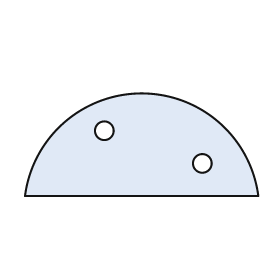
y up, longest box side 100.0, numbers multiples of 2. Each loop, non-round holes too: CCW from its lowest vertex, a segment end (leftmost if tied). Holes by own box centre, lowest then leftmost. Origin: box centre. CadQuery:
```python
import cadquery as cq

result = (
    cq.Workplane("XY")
    .moveTo(-50.0, -22.0)
    .lineTo(50.0, -22.0)
    .threePointArc((0.0, 22.0), (-50.0, -22.0))
    .close()
    .moveTo(26.0, -8.0)
    .circle(4.0)
    .moveTo(-16.0, 6.0)
    .circle(4.0)
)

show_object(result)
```